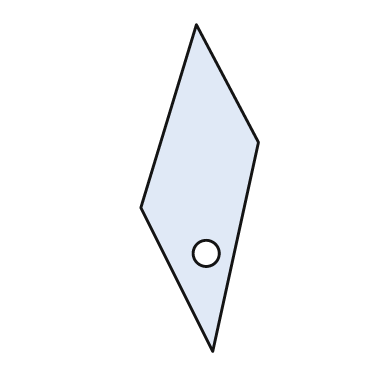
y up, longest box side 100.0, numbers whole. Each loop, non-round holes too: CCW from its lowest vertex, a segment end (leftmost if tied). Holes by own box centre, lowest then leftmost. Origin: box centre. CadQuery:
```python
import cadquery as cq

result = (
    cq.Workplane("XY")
    .moveTo(4.0, -50.0)
    .lineTo(18.0, 14.0)
    .lineTo(-1.0, 50.0)
    .lineTo(-18.0, -6.0)
    .close()
    .moveTo(2.0, -20.0)
    .circle(4.0)
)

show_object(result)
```